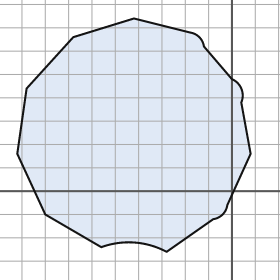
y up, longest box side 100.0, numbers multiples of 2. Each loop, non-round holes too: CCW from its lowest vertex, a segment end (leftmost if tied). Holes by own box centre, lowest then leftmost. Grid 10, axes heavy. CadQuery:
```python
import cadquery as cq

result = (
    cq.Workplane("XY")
    .moveTo(-28.0, -26.0)
    .lineTo(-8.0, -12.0)
    .threePointArc((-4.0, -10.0), (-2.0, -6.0))
    .lineTo(8.0, 16.0)
    .lineTo(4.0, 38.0)
    .threePointArc((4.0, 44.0), (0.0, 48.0))
    .lineTo(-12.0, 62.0)
    .threePointArc((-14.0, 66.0), (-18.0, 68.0))
    .lineTo(-42.0, 74.0)
    .lineTo(-68.0, 66.0)
    .lineTo(-88.0, 44.0)
    .lineTo(-92.0, 16.0)
    .lineTo(-80.0, -10.0)
    .lineTo(-56.0, -24.0)
    .threePointArc((-42.0, -22.0), (-28.0, -26.0))
    .close()
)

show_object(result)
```